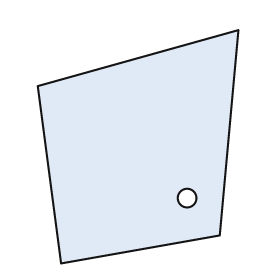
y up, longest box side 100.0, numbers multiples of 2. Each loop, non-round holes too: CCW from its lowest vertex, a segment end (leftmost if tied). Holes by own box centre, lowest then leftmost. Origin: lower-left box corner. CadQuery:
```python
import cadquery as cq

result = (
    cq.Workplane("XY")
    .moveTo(10.0, 0.0)
    .lineTo(78.0, 12.0)
    .lineTo(86.0, 100.0)
    .lineTo(0.0, 76.0)
    .close()
    .moveTo(64.0, 28.0)
    .circle(4.0)
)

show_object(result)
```